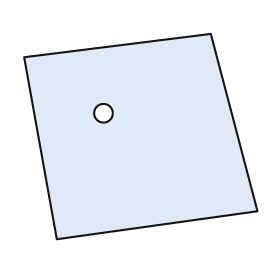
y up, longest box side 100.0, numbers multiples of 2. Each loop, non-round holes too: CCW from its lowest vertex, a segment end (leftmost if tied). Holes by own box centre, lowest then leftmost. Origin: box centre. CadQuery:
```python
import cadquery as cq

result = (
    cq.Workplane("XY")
    .moveTo(-36.0, -44.0)
    .lineTo(50.0, -32.0)
    .lineTo(30.0, 44.0)
    .lineTo(-50.0, 34.0)
    .close()
    .moveTo(-16.0, 10.0)
    .circle(4.0)
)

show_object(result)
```